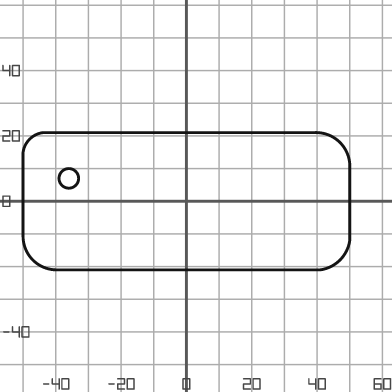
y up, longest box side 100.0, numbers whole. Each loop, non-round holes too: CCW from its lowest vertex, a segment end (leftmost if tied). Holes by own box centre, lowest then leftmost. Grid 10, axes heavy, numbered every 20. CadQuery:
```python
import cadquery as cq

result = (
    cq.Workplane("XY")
    .moveTo(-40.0, -21.0)
    .lineTo(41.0, -21.0)
    .threePointArc((47.0, -18.0), (50.0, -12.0))
    .lineTo(50.0, 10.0)
    .threePointArc((47.0, 18.0), (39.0, 21.0))
    .lineTo(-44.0, 21.0)
    .threePointArc((-48.0, 19.0), (-50.0, 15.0))
    .lineTo(-50.0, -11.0)
    .threePointArc((-47.0, -18.0), (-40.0, -21.0))
    .close()
    .moveTo(-36.0, 7.0)
    .circle(3.0)
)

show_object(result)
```